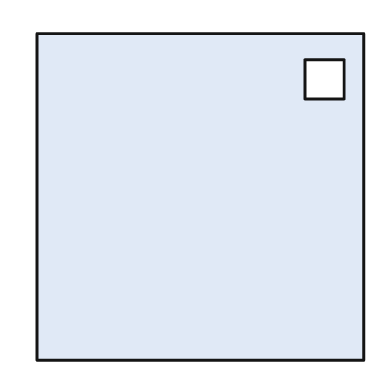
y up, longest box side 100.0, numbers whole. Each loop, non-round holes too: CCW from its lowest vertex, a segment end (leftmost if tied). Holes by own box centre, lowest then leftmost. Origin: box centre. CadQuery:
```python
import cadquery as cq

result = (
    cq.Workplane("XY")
    .moveTo(-50.0, -50.0)
    .lineTo(50.0, -50.0)
    .lineTo(50.0, 50.0)
    .lineTo(-50.0, 50.0)
    .close()
    .moveTo(32.0, 30.0)
    .lineTo(44.0, 30.0)
    .lineTo(44.0, 42.0)
    .lineTo(32.0, 42.0)
    .close()
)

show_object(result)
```